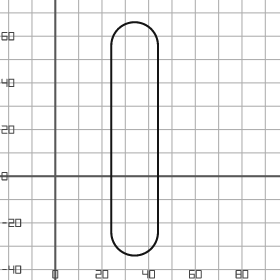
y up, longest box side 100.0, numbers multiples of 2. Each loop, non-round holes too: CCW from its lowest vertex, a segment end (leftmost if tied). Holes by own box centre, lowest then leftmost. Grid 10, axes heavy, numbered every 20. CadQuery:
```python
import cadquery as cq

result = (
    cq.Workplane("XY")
    .moveTo(24.0, -24.0)
    .threePointArc((34.0, -34.0), (44.0, -24.0))
    .lineTo(44.0, 56.0)
    .threePointArc((34.0, 66.0), (24.0, 56.0))
    .close()
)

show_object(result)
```